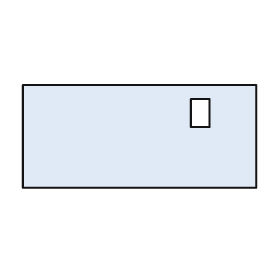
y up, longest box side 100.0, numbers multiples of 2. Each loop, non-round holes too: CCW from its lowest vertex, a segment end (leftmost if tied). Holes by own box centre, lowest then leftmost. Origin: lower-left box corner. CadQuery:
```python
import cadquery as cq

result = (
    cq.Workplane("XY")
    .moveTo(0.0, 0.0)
    .lineTo(100.0, 0.0)
    .lineTo(100.0, 44.0)
    .lineTo(0.0, 44.0)
    .close()
    .moveTo(72.0, 26.0)
    .lineTo(80.0, 26.0)
    .lineTo(80.0, 38.0)
    .lineTo(72.0, 38.0)
    .close()
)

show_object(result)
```